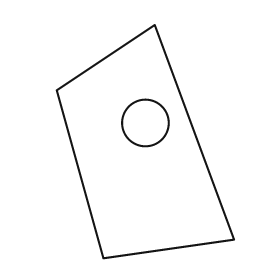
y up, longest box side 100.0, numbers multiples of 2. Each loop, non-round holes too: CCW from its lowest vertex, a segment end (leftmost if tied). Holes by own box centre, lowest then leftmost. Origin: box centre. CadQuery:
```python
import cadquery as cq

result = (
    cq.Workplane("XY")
    .moveTo(-18.0, -50.0)
    .lineTo(38.0, -42.0)
    .lineTo(4.0, 50.0)
    .lineTo(-38.0, 22.0)
    .close()
    .moveTo(0.0, 8.0)
    .circle(10.0)
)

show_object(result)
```